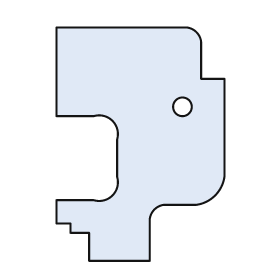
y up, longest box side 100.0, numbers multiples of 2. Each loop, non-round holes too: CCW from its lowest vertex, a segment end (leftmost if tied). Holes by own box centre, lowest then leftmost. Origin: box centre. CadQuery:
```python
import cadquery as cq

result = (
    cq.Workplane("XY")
    .moveTo(-22.0, -50.0)
    .lineTo(4.0, -50.0)
    .lineTo(4.0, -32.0)
    .threePointArc((6.0, -28.0), (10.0, -26.0))
    .lineTo(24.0, -26.0)
    .threePointArc((32.0, -22.0), (36.0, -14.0))
    .lineTo(36.0, 28.0)
    .lineTo(26.0, 28.0)
    .lineTo(26.0, 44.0)
    .threePointArc((24.0, 48.0), (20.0, 50.0))
    .lineTo(-36.0, 50.0)
    .lineTo(-36.0, 12.0)
    .lineTo(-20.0, 12.0)
    .threePointArc((-12.0, 10.0), (-10.0, 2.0))
    .lineTo(-10.0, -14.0)
    .threePointArc((-12.0, -22.0), (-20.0, -24.0))
    .lineTo(-36.0, -24.0)
    .lineTo(-36.0, -34.0)
    .lineTo(-30.0, -34.0)
    .lineTo(-30.0, -38.0)
    .lineTo(-22.0, -38.0)
    .close()
    .moveTo(18.0, 16.0)
    .circle(4.0)
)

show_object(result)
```